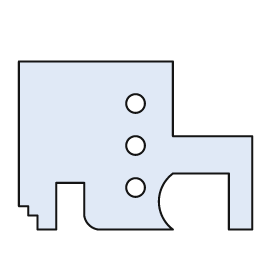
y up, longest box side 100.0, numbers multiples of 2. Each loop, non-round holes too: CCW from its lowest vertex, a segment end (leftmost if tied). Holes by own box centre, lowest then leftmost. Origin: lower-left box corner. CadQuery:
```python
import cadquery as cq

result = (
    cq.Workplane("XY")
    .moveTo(8.0, 0.0)
    .lineTo(16.0, 0.0)
    .lineTo(16.0, 20.0)
    .lineTo(28.0, 20.0)
    .lineTo(28.0, 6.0)
    .threePointArc((30.0, 2.0), (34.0, 0.0))
    .lineTo(66.0, 0.0)
    .threePointArc((60.0, 12.0), (66.0, 24.0))
    .lineTo(90.0, 24.0)
    .lineTo(90.0, 0.0)
    .lineTo(100.0, 0.0)
    .lineTo(100.0, 40.0)
    .lineTo(66.0, 40.0)
    .lineTo(66.0, 72.0)
    .lineTo(0.0, 72.0)
    .lineTo(0.0, 10.0)
    .lineTo(4.0, 10.0)
    .lineTo(4.0, 6.0)
    .lineTo(8.0, 6.0)
    .close()
    .moveTo(50.0, 18.0)
    .circle(4.0)
    .moveTo(50.0, 36.0)
    .circle(4.0)
    .moveTo(50.0, 54.0)
    .circle(4.0)
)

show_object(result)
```